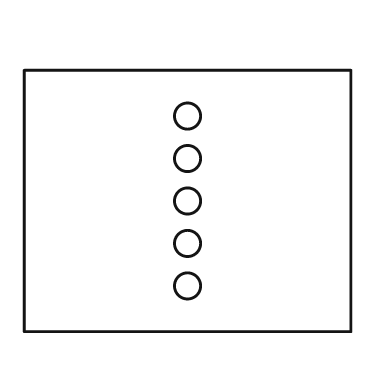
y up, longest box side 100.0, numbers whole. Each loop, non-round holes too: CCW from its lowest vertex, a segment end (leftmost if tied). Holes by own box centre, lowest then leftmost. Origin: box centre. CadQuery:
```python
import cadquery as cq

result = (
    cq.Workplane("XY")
    .moveTo(-50.0, -40.0)
    .lineTo(50.0, -40.0)
    .lineTo(50.0, 40.0)
    .lineTo(-50.0, 40.0)
    .close()
    .moveTo(0.0, -26.0)
    .circle(4.0)
    .moveTo(0.0, -13.0)
    .circle(4.0)
    .moveTo(0.0, 0.0)
    .circle(4.0)
    .moveTo(0.0, 13.0)
    .circle(4.0)
    .moveTo(0.0, 26.0)
    .circle(4.0)
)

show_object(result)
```